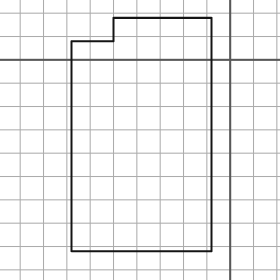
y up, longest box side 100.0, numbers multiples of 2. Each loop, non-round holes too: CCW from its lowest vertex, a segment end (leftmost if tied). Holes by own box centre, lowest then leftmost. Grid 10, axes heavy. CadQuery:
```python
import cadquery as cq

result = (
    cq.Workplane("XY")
    .moveTo(-68.0, -82.0)
    .lineTo(-8.0, -82.0)
    .lineTo(-8.0, 18.0)
    .lineTo(-50.0, 18.0)
    .lineTo(-50.0, 8.0)
    .lineTo(-68.0, 8.0)
    .close()
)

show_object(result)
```